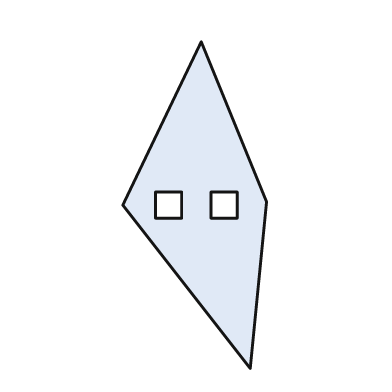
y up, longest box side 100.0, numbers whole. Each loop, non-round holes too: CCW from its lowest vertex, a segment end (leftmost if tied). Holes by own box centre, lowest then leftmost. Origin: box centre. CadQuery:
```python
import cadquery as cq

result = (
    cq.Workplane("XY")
    .moveTo(17.0, -50.0)
    .lineTo(22.0, 1.0)
    .lineTo(2.0, 50.0)
    .lineTo(-22.0, 0.0)
    .close()
    .moveTo(-12.0, -4.0)
    .lineTo(-4.0, -4.0)
    .lineTo(-4.0, 4.0)
    .lineTo(-12.0, 4.0)
    .close()
    .moveTo(5.0, -4.0)
    .lineTo(13.0, -4.0)
    .lineTo(13.0, 4.0)
    .lineTo(5.0, 4.0)
    .close()
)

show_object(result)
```